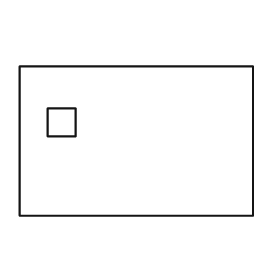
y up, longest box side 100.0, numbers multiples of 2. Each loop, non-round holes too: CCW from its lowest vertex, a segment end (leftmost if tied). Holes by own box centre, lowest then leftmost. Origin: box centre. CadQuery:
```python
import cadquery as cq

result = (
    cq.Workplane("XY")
    .moveTo(-50.0, -32.0)
    .lineTo(50.0, -32.0)
    .lineTo(50.0, 32.0)
    .lineTo(-50.0, 32.0)
    .close()
    .moveTo(-38.0, 2.0)
    .lineTo(-26.0, 2.0)
    .lineTo(-26.0, 14.0)
    .lineTo(-38.0, 14.0)
    .close()
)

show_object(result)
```